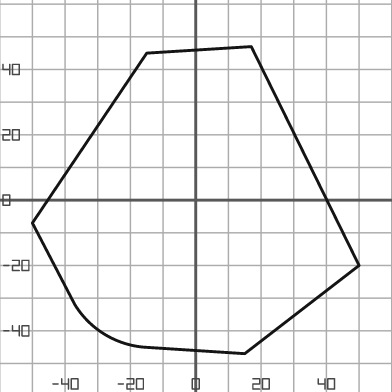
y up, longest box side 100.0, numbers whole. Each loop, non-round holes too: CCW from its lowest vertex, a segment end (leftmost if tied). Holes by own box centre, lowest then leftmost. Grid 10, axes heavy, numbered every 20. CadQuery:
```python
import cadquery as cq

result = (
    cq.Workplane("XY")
    .moveTo(15.0, -47.0)
    .lineTo(50.0, -20.0)
    .lineTo(17.0, 47.0)
    .lineTo(-15.0, 45.0)
    .lineTo(-50.0, -7.0)
    .lineTo(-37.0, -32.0)
    .threePointArc((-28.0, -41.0), (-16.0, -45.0))
    .close()
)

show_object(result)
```